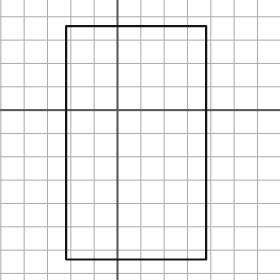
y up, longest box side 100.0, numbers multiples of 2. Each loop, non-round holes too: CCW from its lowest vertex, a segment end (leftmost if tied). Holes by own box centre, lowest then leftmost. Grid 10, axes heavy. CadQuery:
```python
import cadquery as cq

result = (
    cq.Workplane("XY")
    .moveTo(-22.0, -64.0)
    .lineTo(38.0, -64.0)
    .lineTo(38.0, 36.0)
    .lineTo(-22.0, 36.0)
    .close()
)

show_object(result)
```